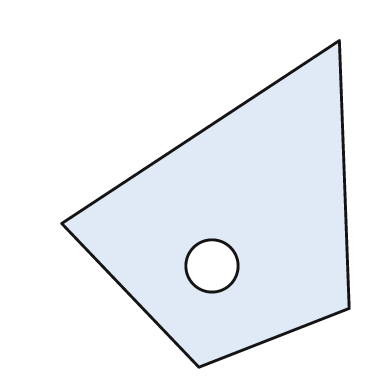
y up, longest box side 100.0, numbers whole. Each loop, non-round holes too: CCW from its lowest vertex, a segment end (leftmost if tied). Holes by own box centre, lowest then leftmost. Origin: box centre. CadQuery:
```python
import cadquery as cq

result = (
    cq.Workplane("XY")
    .moveTo(-2.0, -50.0)
    .lineTo(44.0, -32.0)
    .lineTo(41.0, 50.0)
    .lineTo(-44.0, -6.0)
    .close()
    .moveTo(2.0, -19.0)
    .circle(8.0)
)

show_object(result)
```